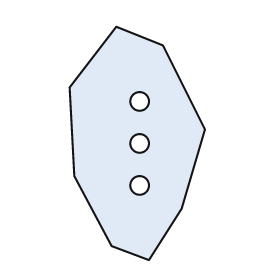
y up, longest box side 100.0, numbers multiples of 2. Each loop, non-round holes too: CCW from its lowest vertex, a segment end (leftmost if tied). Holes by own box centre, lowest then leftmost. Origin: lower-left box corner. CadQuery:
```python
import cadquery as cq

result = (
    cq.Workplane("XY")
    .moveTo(34.0, 0.0)
    .lineTo(48.0, 22.0)
    .lineTo(58.0, 56.0)
    .lineTo(40.0, 92.0)
    .lineTo(20.0, 100.0)
    .lineTo(0.0, 74.0)
    .lineTo(2.0, 36.0)
    .lineTo(18.0, 6.0)
    .close()
    .moveTo(30.0, 32.0)
    .circle(4.0)
    .moveTo(30.0, 50.0)
    .circle(4.0)
    .moveTo(30.0, 68.0)
    .circle(4.0)
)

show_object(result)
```